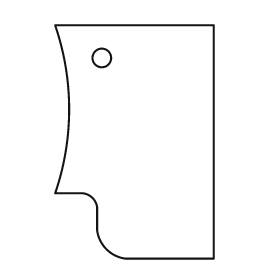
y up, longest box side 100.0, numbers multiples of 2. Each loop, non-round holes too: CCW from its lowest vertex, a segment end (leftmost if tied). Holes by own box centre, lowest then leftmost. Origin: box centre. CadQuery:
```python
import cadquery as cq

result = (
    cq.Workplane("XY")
    .moveTo(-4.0, -50.0)
    .lineTo(34.0, -50.0)
    .lineTo(34.0, 50.0)
    .lineTo(-34.0, 50.0)
    .threePointArc((-28.0, 14.0), (-34.0, -22.0))
    .lineTo(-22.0, -22.0)
    .threePointArc((-18.0, -24.0), (-16.0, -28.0))
    .lineTo(-16.0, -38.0)
    .threePointArc((-12.0, -46.0), (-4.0, -50.0))
    .close()
    .moveTo(-14.0, 36.0)
    .circle(4.0)
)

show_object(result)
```